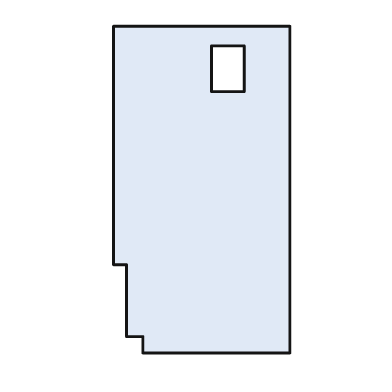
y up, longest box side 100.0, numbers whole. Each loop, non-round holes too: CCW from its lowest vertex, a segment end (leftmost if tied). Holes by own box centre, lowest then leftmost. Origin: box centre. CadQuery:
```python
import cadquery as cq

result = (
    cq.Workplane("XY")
    .moveTo(-18.0, -50.0)
    .lineTo(27.0, -50.0)
    .lineTo(27.0, 50.0)
    .lineTo(-27.0, 50.0)
    .lineTo(-27.0, -23.0)
    .lineTo(-23.0, -23.0)
    .lineTo(-23.0, -45.0)
    .lineTo(-18.0, -45.0)
    .close()
    .moveTo(3.0, 30.0)
    .lineTo(13.0, 30.0)
    .lineTo(13.0, 44.0)
    .lineTo(3.0, 44.0)
    .close()
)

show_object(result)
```